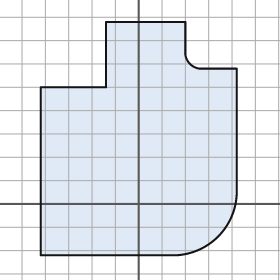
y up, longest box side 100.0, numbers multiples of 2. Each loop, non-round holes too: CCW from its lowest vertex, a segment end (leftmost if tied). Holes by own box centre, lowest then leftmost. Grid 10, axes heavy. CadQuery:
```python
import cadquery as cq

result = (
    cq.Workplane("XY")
    .moveTo(-42.0, -22.0)
    .lineTo(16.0, -22.0)
    .threePointArc((34.0, -14.0), (42.0, 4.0))
    .lineTo(42.0, 58.0)
    .lineTo(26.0, 58.0)
    .threePointArc((22.0, 60.0), (20.0, 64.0))
    .lineTo(20.0, 78.0)
    .lineTo(-14.0, 78.0)
    .lineTo(-14.0, 50.0)
    .lineTo(-42.0, 50.0)
    .close()
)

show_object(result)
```